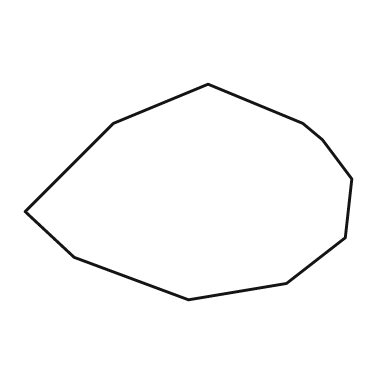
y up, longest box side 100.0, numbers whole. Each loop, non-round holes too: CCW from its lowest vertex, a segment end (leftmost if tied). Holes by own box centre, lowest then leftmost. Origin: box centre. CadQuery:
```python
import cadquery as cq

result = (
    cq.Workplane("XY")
    .moveTo(0.0, -33.0)
    .lineTo(30.0, -28.0)
    .lineTo(48.0, -14.0)
    .lineTo(50.0, 4.0)
    .lineTo(41.0, 16.0)
    .lineTo(35.0, 21.0)
    .lineTo(6.0, 33.0)
    .lineTo(-23.0, 21.0)
    .lineTo(-50.0, -6.0)
    .lineTo(-35.0, -20.0)
    .close()
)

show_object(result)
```